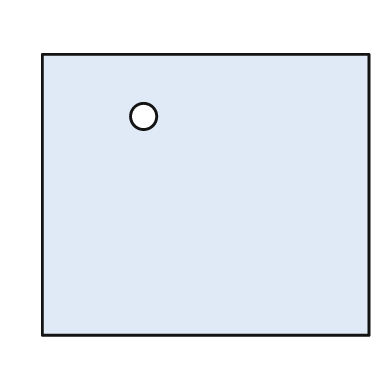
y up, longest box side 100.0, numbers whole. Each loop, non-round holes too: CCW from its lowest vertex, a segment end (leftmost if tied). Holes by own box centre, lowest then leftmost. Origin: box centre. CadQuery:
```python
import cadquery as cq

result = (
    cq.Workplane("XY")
    .moveTo(-50.0, -43.0)
    .lineTo(50.0, -43.0)
    .lineTo(50.0, 43.0)
    .lineTo(-50.0, 43.0)
    .close()
    .moveTo(-19.0, 24.0)
    .circle(4.0)
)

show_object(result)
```